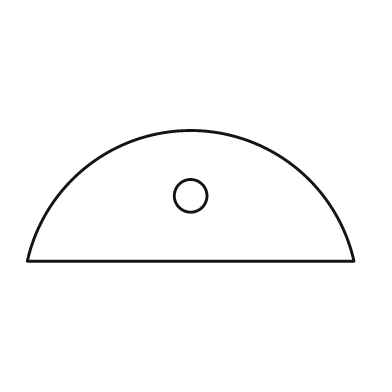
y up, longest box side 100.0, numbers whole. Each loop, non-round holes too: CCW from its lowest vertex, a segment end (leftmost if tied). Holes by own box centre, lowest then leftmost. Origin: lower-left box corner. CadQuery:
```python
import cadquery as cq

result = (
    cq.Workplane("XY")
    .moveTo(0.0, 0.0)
    .lineTo(100.0, 0.0)
    .threePointArc((50.0, 40.0), (0.0, 0.0))
    .close()
    .moveTo(50.0, 20.0)
    .circle(5.0)
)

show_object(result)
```